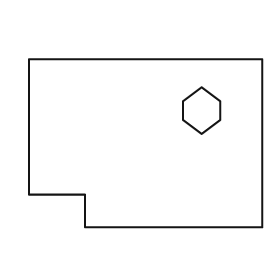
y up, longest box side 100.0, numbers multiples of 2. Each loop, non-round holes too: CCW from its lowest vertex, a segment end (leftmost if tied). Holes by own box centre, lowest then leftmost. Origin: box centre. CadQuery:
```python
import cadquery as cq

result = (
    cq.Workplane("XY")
    .moveTo(-26.0, -36.0)
    .lineTo(50.0, -36.0)
    .lineTo(50.0, 36.0)
    .lineTo(-50.0, 36.0)
    .lineTo(-50.0, -22.0)
    .lineTo(-26.0, -22.0)
    .close()
    .moveTo(24.0, 4.0)
    .lineTo(32.0, 10.0)
    .lineTo(32.0, 18.0)
    .lineTo(24.0, 24.0)
    .lineTo(16.0, 18.0)
    .lineTo(16.0, 10.0)
    .close()
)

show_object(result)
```